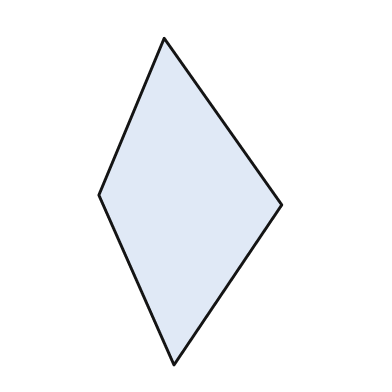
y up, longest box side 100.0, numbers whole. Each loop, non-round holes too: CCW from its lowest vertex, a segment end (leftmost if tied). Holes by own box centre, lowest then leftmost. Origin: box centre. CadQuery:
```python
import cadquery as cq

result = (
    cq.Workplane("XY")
    .moveTo(-5.0, -50.0)
    .lineTo(28.0, -1.0)
    .lineTo(-8.0, 50.0)
    .lineTo(-28.0, 2.0)
    .close()
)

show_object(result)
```